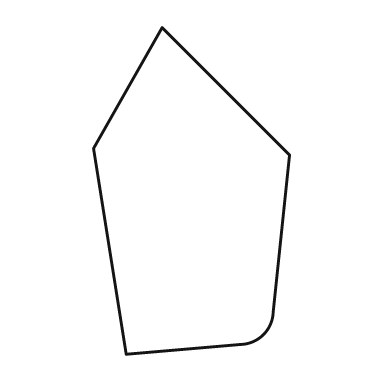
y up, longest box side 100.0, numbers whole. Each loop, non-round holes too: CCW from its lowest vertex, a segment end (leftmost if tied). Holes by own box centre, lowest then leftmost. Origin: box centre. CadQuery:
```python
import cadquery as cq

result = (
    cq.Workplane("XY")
    .moveTo(-20.0, -50.0)
    .lineTo(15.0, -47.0)
    .threePointArc((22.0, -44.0), (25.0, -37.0))
    .lineTo(30.0, 11.0)
    .lineTo(-9.0, 50.0)
    .lineTo(-30.0, 13.0)
    .close()
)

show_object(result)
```